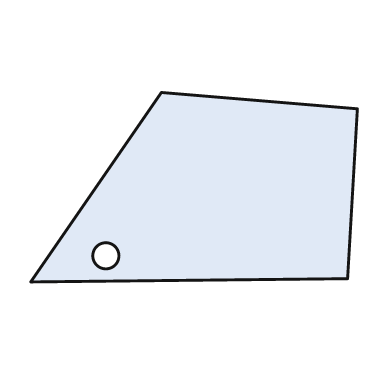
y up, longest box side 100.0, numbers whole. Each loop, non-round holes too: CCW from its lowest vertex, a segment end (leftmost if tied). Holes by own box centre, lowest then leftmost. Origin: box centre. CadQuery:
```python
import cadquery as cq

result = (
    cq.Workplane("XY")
    .moveTo(-50.0, -29.0)
    .lineTo(47.0, -28.0)
    .lineTo(50.0, 24.0)
    .lineTo(-10.0, 29.0)
    .close()
    .moveTo(-27.0, -21.0)
    .circle(4.0)
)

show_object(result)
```